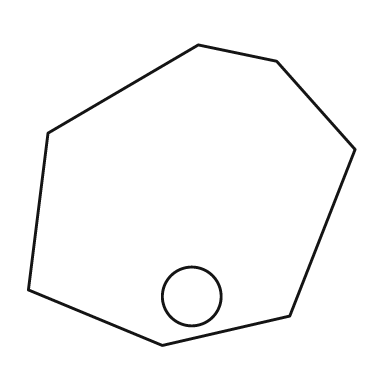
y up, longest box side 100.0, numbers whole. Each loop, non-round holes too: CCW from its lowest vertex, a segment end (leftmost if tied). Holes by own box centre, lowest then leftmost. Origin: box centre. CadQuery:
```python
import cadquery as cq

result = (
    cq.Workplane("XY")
    .moveTo(-9.0, -46.0)
    .lineTo(30.0, -37.0)
    .lineTo(50.0, 14.0)
    .lineTo(26.0, 41.0)
    .lineTo(2.0, 46.0)
    .lineTo(-44.0, 19.0)
    .lineTo(-50.0, -29.0)
    .close()
    .moveTo(0.0, -31.0)
    .circle(9.0)
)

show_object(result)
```